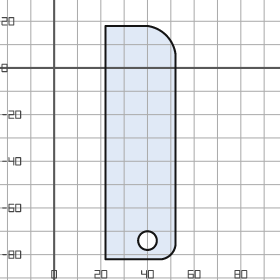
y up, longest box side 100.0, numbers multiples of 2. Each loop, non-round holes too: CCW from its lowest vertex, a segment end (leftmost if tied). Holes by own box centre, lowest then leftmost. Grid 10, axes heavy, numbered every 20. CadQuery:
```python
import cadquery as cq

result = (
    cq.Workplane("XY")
    .moveTo(22.0, -82.0)
    .lineTo(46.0, -82.0)
    .threePointArc((50.0, -80.0), (52.0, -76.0))
    .lineTo(52.0, 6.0)
    .threePointArc((48.0, 14.0), (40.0, 18.0))
    .lineTo(22.0, 18.0)
    .close()
    .moveTo(40.0, -74.0)
    .circle(4.0)
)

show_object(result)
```